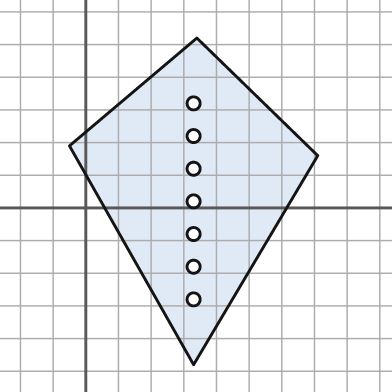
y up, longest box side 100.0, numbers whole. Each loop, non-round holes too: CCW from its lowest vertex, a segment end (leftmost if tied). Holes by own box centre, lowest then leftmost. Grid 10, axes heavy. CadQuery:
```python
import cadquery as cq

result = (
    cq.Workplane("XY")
    .moveTo(33.0, -48.0)
    .lineTo(71.0, 16.0)
    .lineTo(34.0, 52.0)
    .lineTo(-5.0, 19.0)
    .close()
    .moveTo(33.0, -28.0)
    .circle(2.0)
    .moveTo(33.0, -18.0)
    .circle(2.0)
    .moveTo(33.0, -8.0)
    .circle(2.0)
    .moveTo(33.0, 2.0)
    .circle(2.0)
    .moveTo(33.0, 12.0)
    .circle(2.0)
    .moveTo(33.0, 22.0)
    .circle(2.0)
    .moveTo(33.0, 32.0)
    .circle(2.0)
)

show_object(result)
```